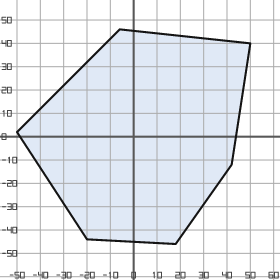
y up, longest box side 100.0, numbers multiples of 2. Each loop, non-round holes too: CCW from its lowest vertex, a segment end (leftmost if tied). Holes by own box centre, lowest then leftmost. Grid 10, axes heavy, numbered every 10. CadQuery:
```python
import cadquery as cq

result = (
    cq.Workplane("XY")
    .moveTo(18.0, -46.0)
    .lineTo(42.0, -12.0)
    .lineTo(50.0, 40.0)
    .lineTo(-6.0, 46.0)
    .lineTo(-50.0, 2.0)
    .lineTo(-20.0, -44.0)
    .close()
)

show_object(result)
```